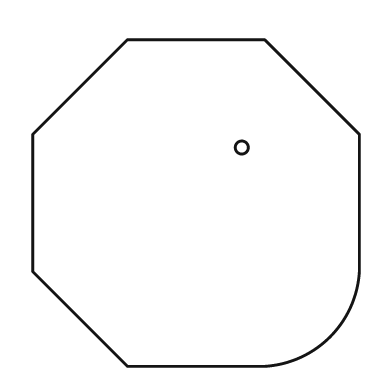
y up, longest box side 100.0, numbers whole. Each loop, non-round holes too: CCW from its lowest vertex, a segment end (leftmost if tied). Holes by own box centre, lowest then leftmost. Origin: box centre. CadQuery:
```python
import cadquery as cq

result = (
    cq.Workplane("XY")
    .moveTo(-21.0, -50.0)
    .lineTo(21.0, -50.0)
    .threePointArc((41.0, -41.0), (50.0, -21.0))
    .lineTo(50.0, 21.0)
    .lineTo(21.0, 50.0)
    .lineTo(-21.0, 50.0)
    .lineTo(-50.0, 21.0)
    .lineTo(-50.0, -21.0)
    .close()
    .moveTo(14.0, 17.0)
    .circle(2.0)
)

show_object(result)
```